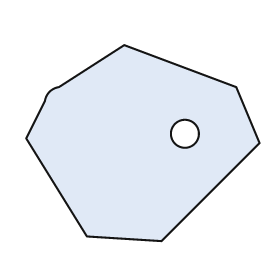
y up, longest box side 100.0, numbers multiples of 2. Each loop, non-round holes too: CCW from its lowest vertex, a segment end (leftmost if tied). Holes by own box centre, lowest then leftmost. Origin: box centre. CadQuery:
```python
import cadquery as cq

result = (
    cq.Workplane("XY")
    .moveTo(8.0, -42.0)
    .lineTo(50.0, 0.0)
    .lineTo(40.0, 24.0)
    .lineTo(-8.0, 42.0)
    .lineTo(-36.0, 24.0)
    .threePointArc((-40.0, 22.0), (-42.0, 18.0))
    .lineTo(-50.0, 2.0)
    .lineTo(-24.0, -40.0)
    .close()
    .moveTo(18.0, 4.0)
    .circle(6.0)
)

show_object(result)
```